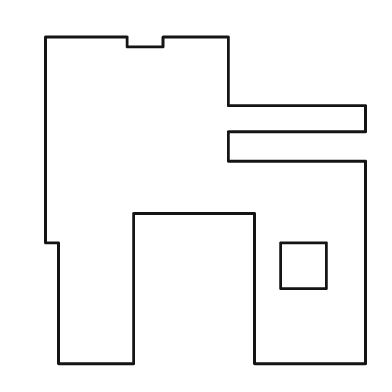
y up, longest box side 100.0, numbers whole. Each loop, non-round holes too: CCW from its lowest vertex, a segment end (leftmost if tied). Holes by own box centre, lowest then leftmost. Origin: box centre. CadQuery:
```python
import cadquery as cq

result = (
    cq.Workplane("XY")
    .moveTo(-45.0, -50.0)
    .lineTo(-22.0, -50.0)
    .lineTo(-22.0, -4.0)
    .lineTo(15.0, -4.0)
    .lineTo(15.0, -50.0)
    .lineTo(49.0, -50.0)
    .lineTo(49.0, 12.0)
    .lineTo(7.0, 12.0)
    .lineTo(7.0, 21.0)
    .lineTo(49.0, 21.0)
    .lineTo(49.0, 29.0)
    .lineTo(7.0, 29.0)
    .lineTo(7.0, 50.0)
    .lineTo(-13.0, 50.0)
    .lineTo(-13.0, 47.0)
    .lineTo(-24.0, 47.0)
    .lineTo(-24.0, 50.0)
    .lineTo(-49.0, 50.0)
    .lineTo(-49.0, -13.0)
    .lineTo(-45.0, -13.0)
    .close()
    .moveTo(23.0, -27.0)
    .lineTo(37.0, -27.0)
    .lineTo(37.0, -13.0)
    .lineTo(23.0, -13.0)
    .close()
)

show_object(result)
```